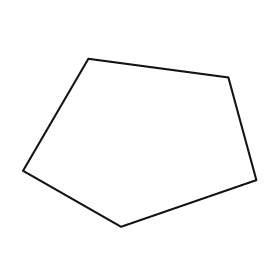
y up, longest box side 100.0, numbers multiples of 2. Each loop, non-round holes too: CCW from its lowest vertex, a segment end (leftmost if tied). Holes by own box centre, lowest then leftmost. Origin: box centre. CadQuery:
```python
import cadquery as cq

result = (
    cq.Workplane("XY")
    .moveTo(-8.0, -36.0)
    .lineTo(50.0, -16.0)
    .lineTo(38.0, 28.0)
    .lineTo(-22.0, 36.0)
    .lineTo(-50.0, -12.0)
    .close()
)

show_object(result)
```